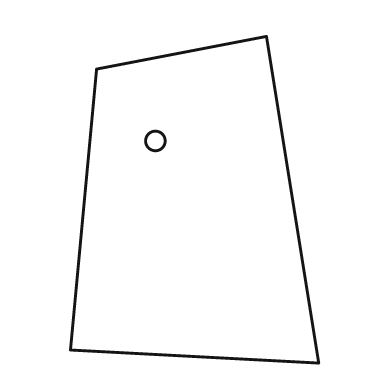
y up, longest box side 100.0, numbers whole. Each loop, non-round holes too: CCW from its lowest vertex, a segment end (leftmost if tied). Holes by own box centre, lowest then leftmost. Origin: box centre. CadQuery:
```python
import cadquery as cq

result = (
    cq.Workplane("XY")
    .moveTo(38.0, -50.0)
    .lineTo(22.0, 50.0)
    .lineTo(-30.0, 40.0)
    .lineTo(-38.0, -46.0)
    .close()
    .moveTo(-12.0, 18.0)
    .circle(3.0)
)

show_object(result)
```